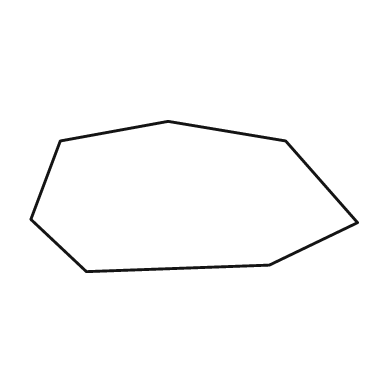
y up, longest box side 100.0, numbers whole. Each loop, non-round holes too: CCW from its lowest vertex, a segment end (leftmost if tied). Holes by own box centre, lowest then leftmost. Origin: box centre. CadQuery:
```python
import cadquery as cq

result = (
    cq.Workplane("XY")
    .moveTo(-33.0, -23.0)
    .lineTo(23.0, -21.0)
    .lineTo(50.0, -8.0)
    .lineTo(28.0, 17.0)
    .lineTo(-8.0, 23.0)
    .lineTo(-41.0, 17.0)
    .lineTo(-50.0, -7.0)
    .close()
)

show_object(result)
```